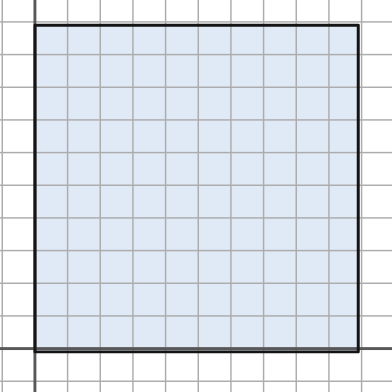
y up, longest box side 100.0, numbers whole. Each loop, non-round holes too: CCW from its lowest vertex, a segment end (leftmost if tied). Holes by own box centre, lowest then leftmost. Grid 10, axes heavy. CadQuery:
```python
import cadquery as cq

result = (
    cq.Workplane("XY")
    .moveTo(0.0, -1.0)
    .lineTo(99.0, -1.0)
    .lineTo(99.0, 99.0)
    .lineTo(0.0, 99.0)
    .close()
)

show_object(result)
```